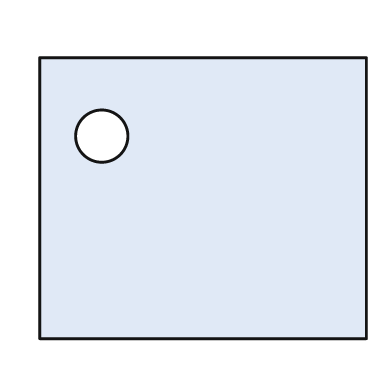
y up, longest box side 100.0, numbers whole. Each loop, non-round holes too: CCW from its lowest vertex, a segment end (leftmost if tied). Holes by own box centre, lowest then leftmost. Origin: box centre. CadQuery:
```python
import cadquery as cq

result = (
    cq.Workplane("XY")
    .moveTo(-50.0, -43.0)
    .lineTo(50.0, -43.0)
    .lineTo(50.0, 43.0)
    .lineTo(-50.0, 43.0)
    .close()
    .moveTo(-31.0, 19.0)
    .circle(8.0)
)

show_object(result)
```